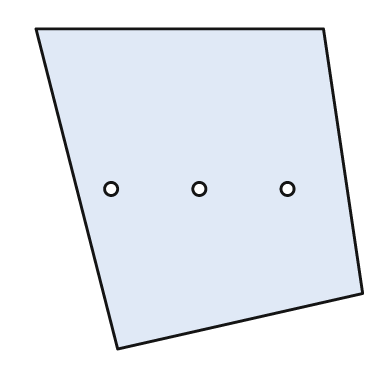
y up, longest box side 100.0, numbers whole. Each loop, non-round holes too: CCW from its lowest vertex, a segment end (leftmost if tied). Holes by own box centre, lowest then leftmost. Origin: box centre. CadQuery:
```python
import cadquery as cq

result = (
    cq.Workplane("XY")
    .moveTo(-25.0, -49.0)
    .lineTo(50.0, -32.0)
    .lineTo(38.0, 49.0)
    .lineTo(-50.0, 49.0)
    .close()
    .moveTo(-27.0, 0.0)
    .circle(2.0)
    .moveTo(0.0, 0.0)
    .circle(2.0)
    .moveTo(27.0, 0.0)
    .circle(2.0)
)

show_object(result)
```